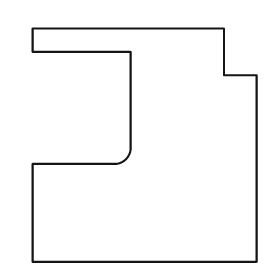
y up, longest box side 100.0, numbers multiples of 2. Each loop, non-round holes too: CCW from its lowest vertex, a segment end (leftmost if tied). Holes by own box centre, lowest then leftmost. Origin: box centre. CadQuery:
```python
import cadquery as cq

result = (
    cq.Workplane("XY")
    .moveTo(-48.0, -50.0)
    .lineTo(48.0, -50.0)
    .lineTo(48.0, 30.0)
    .lineTo(34.0, 30.0)
    .lineTo(34.0, 50.0)
    .lineTo(-48.0, 50.0)
    .lineTo(-48.0, 40.0)
    .lineTo(-6.0, 40.0)
    .lineTo(-6.0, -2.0)
    .threePointArc((-8.0, -6.0), (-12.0, -8.0))
    .lineTo(-48.0, -8.0)
    .close()
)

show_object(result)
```